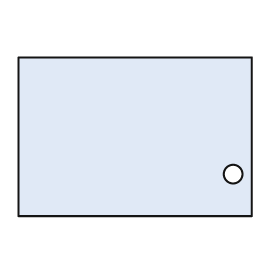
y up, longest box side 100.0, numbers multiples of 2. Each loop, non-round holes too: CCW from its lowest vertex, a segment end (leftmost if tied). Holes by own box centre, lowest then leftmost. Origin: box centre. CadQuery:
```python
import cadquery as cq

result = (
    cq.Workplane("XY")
    .moveTo(-50.0, -34.0)
    .lineTo(50.0, -34.0)
    .lineTo(50.0, 34.0)
    .lineTo(-50.0, 34.0)
    .close()
    .moveTo(42.0, -16.0)
    .circle(4.0)
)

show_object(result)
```